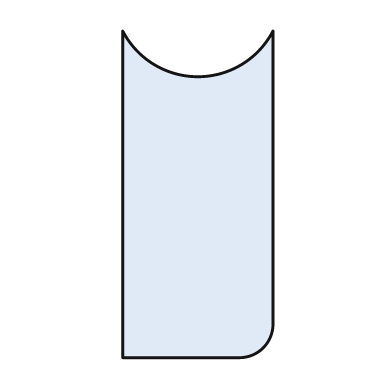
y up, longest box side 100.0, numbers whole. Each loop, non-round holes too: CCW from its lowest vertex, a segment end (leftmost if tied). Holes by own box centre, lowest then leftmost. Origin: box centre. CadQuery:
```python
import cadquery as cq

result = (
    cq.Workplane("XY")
    .moveTo(-23.0, -50.0)
    .lineTo(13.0, -50.0)
    .threePointArc((20.0, -47.0), (23.0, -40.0))
    .lineTo(23.0, 50.0)
    .threePointArc((0.0, 36.0), (-23.0, 50.0))
    .close()
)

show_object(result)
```